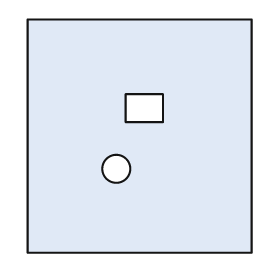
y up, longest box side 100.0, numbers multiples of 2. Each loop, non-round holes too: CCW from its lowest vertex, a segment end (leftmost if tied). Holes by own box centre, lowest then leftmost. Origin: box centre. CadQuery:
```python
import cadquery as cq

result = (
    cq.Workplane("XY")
    .moveTo(-48.0, -50.0)
    .lineTo(48.0, -50.0)
    .lineTo(48.0, 50.0)
    .lineTo(-48.0, 50.0)
    .close()
    .moveTo(-10.0, -14.0)
    .circle(6.0)
    .moveTo(-6.0, 6.0)
    .lineTo(10.0, 6.0)
    .lineTo(10.0, 18.0)
    .lineTo(-6.0, 18.0)
    .close()
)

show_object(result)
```